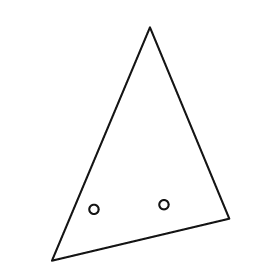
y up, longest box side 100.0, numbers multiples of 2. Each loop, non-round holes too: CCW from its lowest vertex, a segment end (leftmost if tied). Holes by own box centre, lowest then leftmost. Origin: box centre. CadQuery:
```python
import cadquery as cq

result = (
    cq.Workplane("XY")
    .moveTo(-38.0, -50.0)
    .lineTo(38.0, -32.0)
    .lineTo(4.0, 50.0)
    .close()
    .moveTo(-20.0, -28.0)
    .circle(2.0)
    .moveTo(10.0, -26.0)
    .circle(2.0)
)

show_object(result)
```